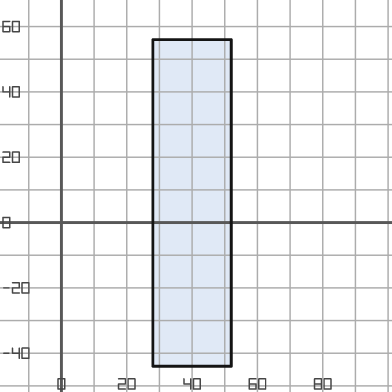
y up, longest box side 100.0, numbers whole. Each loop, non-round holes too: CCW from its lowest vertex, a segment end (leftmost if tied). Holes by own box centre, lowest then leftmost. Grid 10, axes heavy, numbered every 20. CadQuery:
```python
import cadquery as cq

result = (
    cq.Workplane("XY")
    .moveTo(28.0, -44.0)
    .lineTo(52.0, -44.0)
    .lineTo(52.0, 56.0)
    .lineTo(28.0, 56.0)
    .close()
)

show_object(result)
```